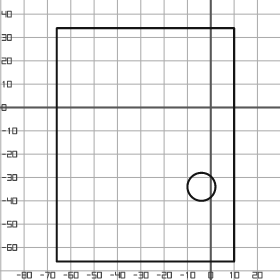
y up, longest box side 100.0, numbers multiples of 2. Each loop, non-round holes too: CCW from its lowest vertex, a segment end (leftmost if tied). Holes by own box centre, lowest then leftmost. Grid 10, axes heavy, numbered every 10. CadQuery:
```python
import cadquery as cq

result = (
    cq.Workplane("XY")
    .moveTo(-66.0, -66.0)
    .lineTo(10.0, -66.0)
    .lineTo(10.0, 34.0)
    .lineTo(-66.0, 34.0)
    .close()
    .moveTo(-4.0, -34.0)
    .circle(6.0)
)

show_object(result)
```